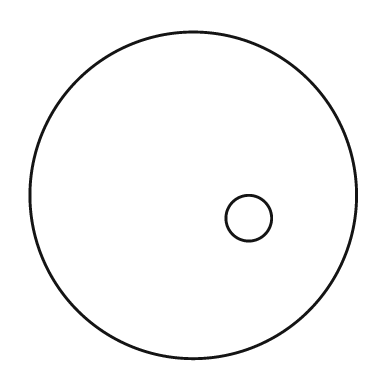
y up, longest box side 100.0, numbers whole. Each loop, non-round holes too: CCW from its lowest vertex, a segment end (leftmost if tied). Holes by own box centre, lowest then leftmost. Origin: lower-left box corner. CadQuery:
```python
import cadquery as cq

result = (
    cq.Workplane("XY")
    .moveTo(50.0, 50.0)
    .circle(50.0)
    .moveTo(67.0, 43.0)
    .circle(7.0)
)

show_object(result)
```